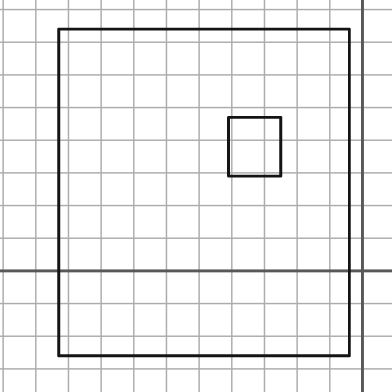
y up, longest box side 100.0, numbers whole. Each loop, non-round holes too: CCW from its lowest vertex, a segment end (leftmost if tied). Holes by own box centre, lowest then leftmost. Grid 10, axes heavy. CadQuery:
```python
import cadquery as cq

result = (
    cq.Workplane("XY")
    .moveTo(-93.0, -26.0)
    .lineTo(-4.0, -26.0)
    .lineTo(-4.0, 74.0)
    .lineTo(-93.0, 74.0)
    .close()
    .moveTo(-41.0, 29.0)
    .lineTo(-25.0, 29.0)
    .lineTo(-25.0, 47.0)
    .lineTo(-41.0, 47.0)
    .close()
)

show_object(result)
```